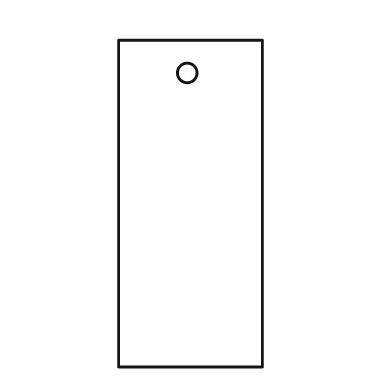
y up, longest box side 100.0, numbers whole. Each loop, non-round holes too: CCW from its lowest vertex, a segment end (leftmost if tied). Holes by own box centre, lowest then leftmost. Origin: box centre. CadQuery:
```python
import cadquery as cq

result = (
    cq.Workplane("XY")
    .moveTo(-22.0, -50.0)
    .lineTo(22.0, -50.0)
    .lineTo(22.0, 50.0)
    .lineTo(-22.0, 50.0)
    .close()
    .moveTo(-1.0, 40.0)
    .circle(3.0)
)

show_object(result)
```